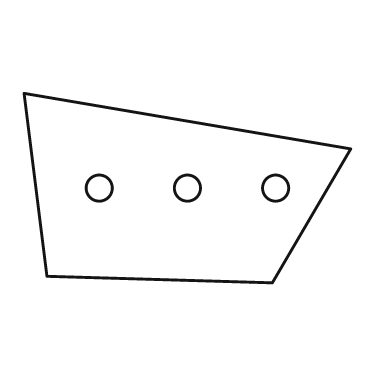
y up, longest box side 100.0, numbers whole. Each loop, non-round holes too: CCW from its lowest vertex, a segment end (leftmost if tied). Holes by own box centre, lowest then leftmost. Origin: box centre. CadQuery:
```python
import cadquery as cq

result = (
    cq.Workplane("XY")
    .moveTo(26.0, -29.0)
    .lineTo(50.0, 12.0)
    .lineTo(-50.0, 29.0)
    .lineTo(-43.0, -27.0)
    .close()
    .moveTo(-27.0, 0.0)
    .circle(4.0)
    .moveTo(0.0, 0.0)
    .circle(4.0)
    .moveTo(27.0, 0.0)
    .circle(4.0)
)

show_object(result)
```